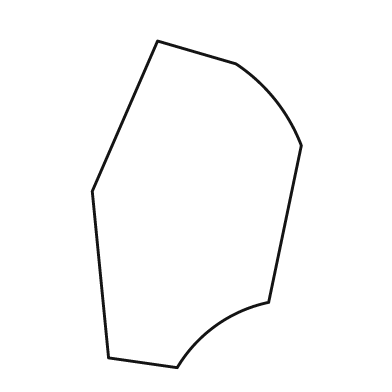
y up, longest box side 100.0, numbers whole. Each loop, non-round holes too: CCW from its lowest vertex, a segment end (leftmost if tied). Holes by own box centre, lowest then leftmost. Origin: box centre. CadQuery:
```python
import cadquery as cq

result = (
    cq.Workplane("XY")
    .moveTo(-6.0, -50.0)
    .threePointArc((6.0, -37.0), (22.0, -30.0))
    .lineTo(32.0, 18.0)
    .threePointArc((24.0, 32.0), (12.0, 43.0))
    .lineTo(-12.0, 50.0)
    .lineTo(-32.0, 4.0)
    .lineTo(-27.0, -47.0)
    .close()
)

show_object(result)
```